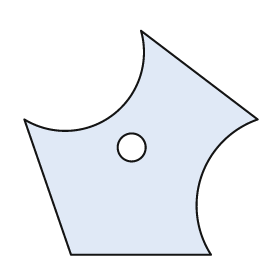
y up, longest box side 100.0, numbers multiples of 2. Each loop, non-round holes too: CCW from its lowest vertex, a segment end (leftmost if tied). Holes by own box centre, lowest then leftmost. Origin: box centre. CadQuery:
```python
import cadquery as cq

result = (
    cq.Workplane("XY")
    .moveTo(-30.0, -48.0)
    .lineTo(30.0, -48.0)
    .threePointArc((26.0, -14.0), (50.0, 10.0))
    .lineTo(0.0, 48.0)
    .threePointArc((-12.0, 12.0), (-50.0, 10.0))
    .close()
    .moveTo(-4.0, -2.0)
    .circle(6.0)
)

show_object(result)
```